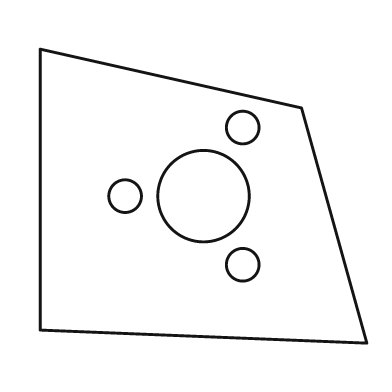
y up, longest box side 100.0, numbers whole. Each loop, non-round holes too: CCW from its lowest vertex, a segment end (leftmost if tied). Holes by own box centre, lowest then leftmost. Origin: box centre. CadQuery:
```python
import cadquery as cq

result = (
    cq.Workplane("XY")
    .moveTo(50.0, -45.0)
    .lineTo(30.0, 27.0)
    .lineTo(-50.0, 45.0)
    .lineTo(-50.0, -41.0)
    .close()
    .moveTo(12.0, -21.0)
    .circle(5.0)
    .moveTo(-24.0, 0.0)
    .circle(5.0)
    .moveTo(0.0, 0.0)
    .circle(14.0)
    .moveTo(12.0, 21.0)
    .circle(5.0)
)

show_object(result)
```